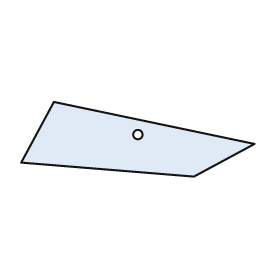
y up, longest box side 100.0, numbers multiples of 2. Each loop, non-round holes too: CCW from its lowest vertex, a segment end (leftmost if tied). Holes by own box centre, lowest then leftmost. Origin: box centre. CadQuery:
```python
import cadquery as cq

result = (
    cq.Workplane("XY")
    .moveTo(24.0, -16.0)
    .lineTo(50.0, -2.0)
    .lineTo(-36.0, 16.0)
    .lineTo(-50.0, -10.0)
    .close()
    .moveTo(0.0, 2.0)
    .circle(2.0)
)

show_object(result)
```